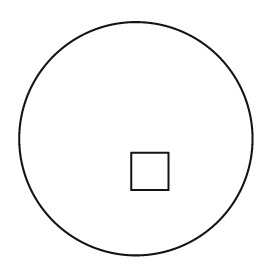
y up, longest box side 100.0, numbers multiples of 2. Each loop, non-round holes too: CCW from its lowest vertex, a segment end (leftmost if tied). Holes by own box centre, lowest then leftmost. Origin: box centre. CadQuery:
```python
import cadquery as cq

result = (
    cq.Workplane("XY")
    .moveTo(0.0, 0.0)
    .circle(50.0)
    .moveTo(-2.0, -22.0)
    .lineTo(14.0, -22.0)
    .lineTo(14.0, -6.0)
    .lineTo(-2.0, -6.0)
    .close()
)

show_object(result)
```